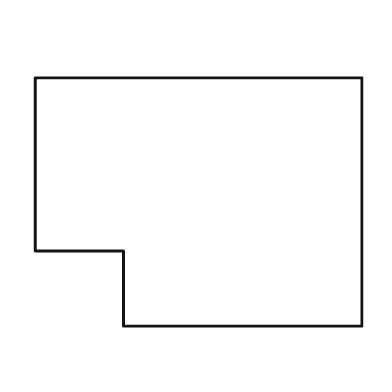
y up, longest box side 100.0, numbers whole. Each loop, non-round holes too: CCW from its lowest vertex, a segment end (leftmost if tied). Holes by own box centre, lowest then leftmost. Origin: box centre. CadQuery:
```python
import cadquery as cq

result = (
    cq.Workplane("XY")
    .moveTo(-23.0, -38.0)
    .lineTo(50.0, -38.0)
    .lineTo(50.0, 38.0)
    .lineTo(-50.0, 38.0)
    .lineTo(-50.0, -15.0)
    .lineTo(-23.0, -15.0)
    .close()
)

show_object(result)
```